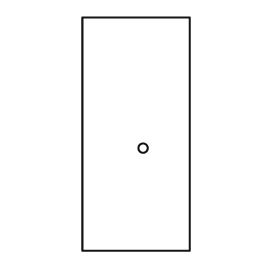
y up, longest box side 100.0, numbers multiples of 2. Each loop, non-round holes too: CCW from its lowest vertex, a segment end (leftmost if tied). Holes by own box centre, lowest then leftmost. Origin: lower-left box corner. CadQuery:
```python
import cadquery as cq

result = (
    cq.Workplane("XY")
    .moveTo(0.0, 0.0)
    .lineTo(46.0, 0.0)
    .lineTo(46.0, 100.0)
    .lineTo(0.0, 100.0)
    .close()
    .moveTo(26.0, 44.0)
    .circle(2.0)
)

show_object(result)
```